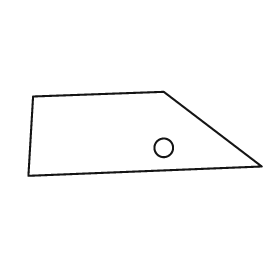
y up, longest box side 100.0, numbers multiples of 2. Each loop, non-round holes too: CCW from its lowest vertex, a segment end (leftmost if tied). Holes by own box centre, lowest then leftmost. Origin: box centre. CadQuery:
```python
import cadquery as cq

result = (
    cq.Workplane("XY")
    .moveTo(-50.0, -18.0)
    .lineTo(50.0, -14.0)
    .lineTo(8.0, 18.0)
    .lineTo(-48.0, 16.0)
    .close()
    .moveTo(8.0, -6.0)
    .circle(4.0)
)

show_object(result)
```